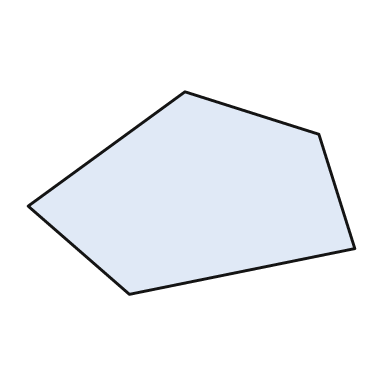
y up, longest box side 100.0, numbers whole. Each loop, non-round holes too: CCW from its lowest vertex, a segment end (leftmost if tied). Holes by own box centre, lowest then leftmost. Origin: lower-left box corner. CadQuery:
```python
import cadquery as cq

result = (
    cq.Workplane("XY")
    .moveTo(31.0, 0.0)
    .lineTo(100.0, 14.0)
    .lineTo(89.0, 49.0)
    .lineTo(48.0, 62.0)
    .lineTo(0.0, 27.0)
    .close()
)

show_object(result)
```